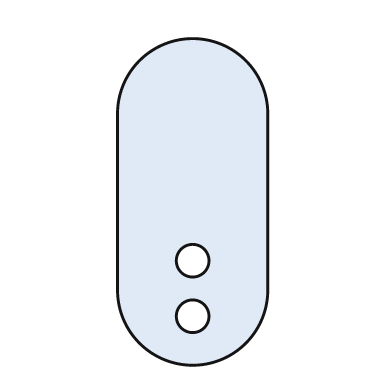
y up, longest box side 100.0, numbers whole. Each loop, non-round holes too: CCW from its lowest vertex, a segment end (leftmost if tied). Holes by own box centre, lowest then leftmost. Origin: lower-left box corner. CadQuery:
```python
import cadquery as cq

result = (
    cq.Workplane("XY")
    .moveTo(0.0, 23.0)
    .threePointArc((23.0, 0.0), (46.0, 23.0))
    .lineTo(46.0, 77.0)
    .threePointArc((23.0, 100.0), (0.0, 77.0))
    .close()
    .moveTo(23.0, 15.0)
    .circle(5.0)
    .moveTo(23.0, 32.0)
    .circle(5.0)
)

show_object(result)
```